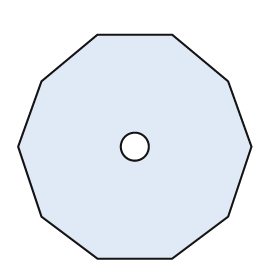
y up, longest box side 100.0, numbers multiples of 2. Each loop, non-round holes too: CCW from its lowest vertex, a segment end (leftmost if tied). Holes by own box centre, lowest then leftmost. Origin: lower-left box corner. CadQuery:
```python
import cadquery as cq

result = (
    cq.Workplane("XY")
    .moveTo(34.0, 0.0)
    .lineTo(66.0, 0.0)
    .lineTo(90.0, 18.0)
    .lineTo(100.0, 48.0)
    .lineTo(90.0, 76.0)
    .lineTo(66.0, 96.0)
    .lineTo(34.0, 96.0)
    .lineTo(10.0, 76.0)
    .lineTo(0.0, 48.0)
    .lineTo(10.0, 18.0)
    .close()
    .moveTo(50.0, 48.0)
    .circle(6.0)
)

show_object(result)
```